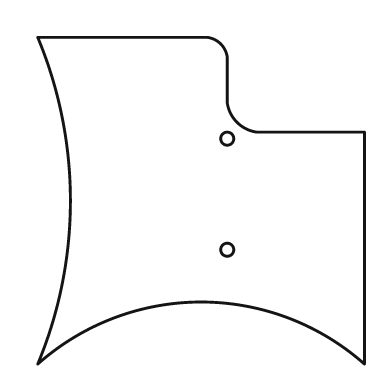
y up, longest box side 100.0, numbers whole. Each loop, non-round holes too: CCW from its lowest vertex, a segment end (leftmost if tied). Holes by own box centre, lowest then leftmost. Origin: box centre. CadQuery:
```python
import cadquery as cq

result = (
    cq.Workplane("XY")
    .moveTo(-50.0, -50.0)
    .threePointArc((0.0, -31.0), (50.0, -50.0))
    .lineTo(50.0, 21.0)
    .lineTo(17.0, 21.0)
    .threePointArc((11.0, 24.0), (8.0, 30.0))
    .lineTo(8.0, 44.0)
    .threePointArc((6.0, 48.0), (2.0, 50.0))
    .lineTo(-50.0, 50.0)
    .threePointArc((-40.0, 0.0), (-50.0, -50.0))
    .close()
    .moveTo(8.0, -15.0)
    .circle(2.0)
    .moveTo(8.0, 19.0)
    .circle(2.0)
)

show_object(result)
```